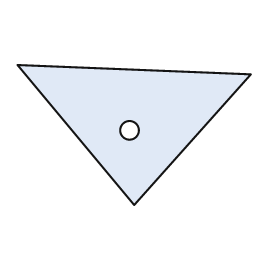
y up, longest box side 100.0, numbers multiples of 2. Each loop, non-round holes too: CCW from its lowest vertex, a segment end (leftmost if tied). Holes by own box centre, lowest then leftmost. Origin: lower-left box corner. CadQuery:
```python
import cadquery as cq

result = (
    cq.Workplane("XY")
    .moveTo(50.0, 0.0)
    .lineTo(100.0, 56.0)
    .lineTo(0.0, 60.0)
    .close()
    .moveTo(48.0, 32.0)
    .circle(4.0)
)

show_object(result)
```